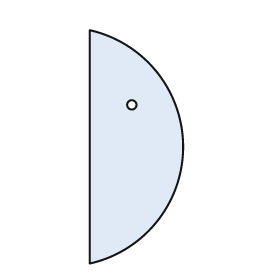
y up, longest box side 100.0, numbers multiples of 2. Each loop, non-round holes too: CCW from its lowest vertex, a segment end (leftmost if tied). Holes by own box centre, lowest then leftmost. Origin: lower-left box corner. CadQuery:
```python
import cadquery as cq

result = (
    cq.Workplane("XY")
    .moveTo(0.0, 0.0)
    .threePointArc((40.0, 50.0), (0.0, 100.0))
    .close()
    .moveTo(18.0, 68.0)
    .circle(2.0)
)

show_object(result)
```